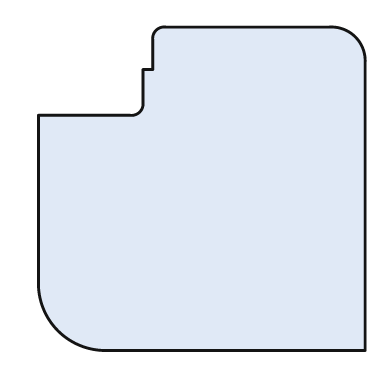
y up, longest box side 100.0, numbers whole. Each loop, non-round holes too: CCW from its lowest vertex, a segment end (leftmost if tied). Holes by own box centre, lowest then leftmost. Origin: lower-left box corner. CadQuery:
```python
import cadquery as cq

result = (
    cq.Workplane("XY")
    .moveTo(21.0, 0.0)
    .lineTo(100.0, 0.0)
    .lineTo(100.0, 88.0)
    .threePointArc((97.0, 96.0), (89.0, 99.0))
    .lineTo(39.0, 99.0)
    .threePointArc((36.0, 98.0), (35.0, 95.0))
    .lineTo(35.0, 86.0)
    .lineTo(32.0, 86.0)
    .lineTo(32.0, 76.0)
    .threePointArc((31.0, 73.0), (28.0, 72.0))
    .lineTo(0.0, 72.0)
    .lineTo(0.0, 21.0)
    .threePointArc((6.0, 6.0), (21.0, 0.0))
    .close()
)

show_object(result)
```